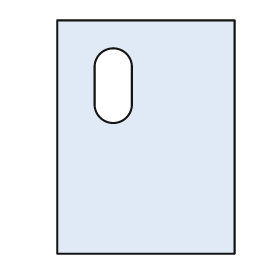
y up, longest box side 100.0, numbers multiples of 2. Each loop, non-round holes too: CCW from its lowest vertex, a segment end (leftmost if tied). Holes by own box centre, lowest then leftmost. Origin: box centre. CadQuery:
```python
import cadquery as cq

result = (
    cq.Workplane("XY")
    .moveTo(-38.0, -50.0)
    .lineTo(38.0, -50.0)
    .lineTo(38.0, 50.0)
    .lineTo(-38.0, 50.0)
    .close()
    .moveTo(-22.0, 14.0)
    .threePointArc((-14.0, 6.0), (-6.0, 14.0))
    .lineTo(-6.0, 30.0)
    .threePointArc((-14.0, 38.0), (-22.0, 30.0))
    .close()
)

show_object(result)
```